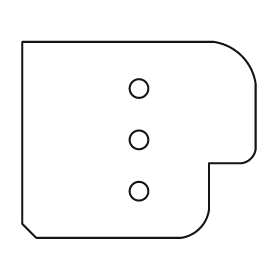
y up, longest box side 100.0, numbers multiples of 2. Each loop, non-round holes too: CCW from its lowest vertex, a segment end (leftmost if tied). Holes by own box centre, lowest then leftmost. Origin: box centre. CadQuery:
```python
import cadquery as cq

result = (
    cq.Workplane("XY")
    .moveTo(-44.0, -42.0)
    .lineTo(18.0, -42.0)
    .threePointArc((26.0, -38.0), (30.0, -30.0))
    .lineTo(30.0, -10.0)
    .lineTo(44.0, -10.0)
    .threePointArc((48.0, -8.0), (50.0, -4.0))
    .lineTo(50.0, 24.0)
    .threePointArc((44.0, 36.0), (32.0, 42.0))
    .lineTo(-50.0, 42.0)
    .lineTo(-50.0, -36.0)
    .close()
    .moveTo(0.0, -22.0)
    .circle(4.0)
    .moveTo(0.0, 0.0)
    .circle(4.0)
    .moveTo(0.0, 22.0)
    .circle(4.0)
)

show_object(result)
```